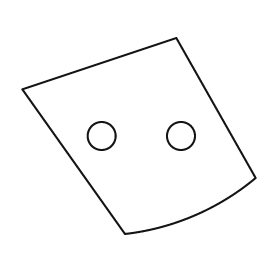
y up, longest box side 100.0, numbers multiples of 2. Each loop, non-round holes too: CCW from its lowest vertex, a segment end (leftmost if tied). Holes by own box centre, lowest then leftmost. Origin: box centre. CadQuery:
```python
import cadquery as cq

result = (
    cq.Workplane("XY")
    .moveTo(-6.0, -42.0)
    .threePointArc((24.0, -34.0), (50.0, -18.0))
    .lineTo(16.0, 42.0)
    .lineTo(-50.0, 20.0)
    .close()
    .moveTo(-16.0, 0.0)
    .circle(6.0)
    .moveTo(18.0, 0.0)
    .circle(6.0)
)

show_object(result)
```